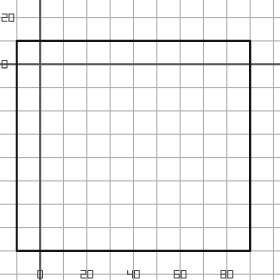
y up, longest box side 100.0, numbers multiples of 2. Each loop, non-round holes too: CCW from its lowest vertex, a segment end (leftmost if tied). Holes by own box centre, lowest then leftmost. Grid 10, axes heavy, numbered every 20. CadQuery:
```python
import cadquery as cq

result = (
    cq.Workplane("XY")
    .moveTo(-10.0, -80.0)
    .lineTo(90.0, -80.0)
    .lineTo(90.0, 10.0)
    .lineTo(-10.0, 10.0)
    .close()
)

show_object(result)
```